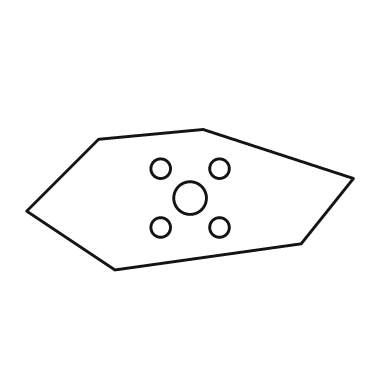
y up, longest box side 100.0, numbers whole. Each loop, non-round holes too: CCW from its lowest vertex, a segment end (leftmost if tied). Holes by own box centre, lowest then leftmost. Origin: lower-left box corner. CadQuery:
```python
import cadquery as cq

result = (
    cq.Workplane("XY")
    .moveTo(27.0, 0.0)
    .lineTo(84.0, 8.0)
    .lineTo(100.0, 28.0)
    .lineTo(54.0, 43.0)
    .lineTo(22.0, 40.0)
    .lineTo(0.0, 18.0)
    .close()
    .moveTo(41.0, 13.0)
    .circle(3.0)
    .moveTo(59.0, 13.0)
    .circle(3.0)
    .moveTo(50.0, 22.0)
    .circle(5.0)
    .moveTo(41.0, 31.0)
    .circle(3.0)
    .moveTo(59.0, 31.0)
    .circle(3.0)
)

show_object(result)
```